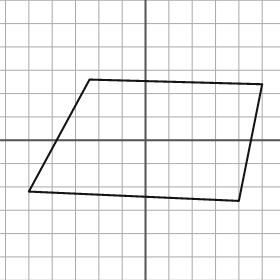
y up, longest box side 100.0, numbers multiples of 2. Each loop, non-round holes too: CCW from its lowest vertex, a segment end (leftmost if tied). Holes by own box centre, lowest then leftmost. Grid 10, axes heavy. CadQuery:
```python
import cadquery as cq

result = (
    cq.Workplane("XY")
    .moveTo(40.0, -26.0)
    .lineTo(50.0, 24.0)
    .lineTo(-24.0, 26.0)
    .lineTo(-50.0, -22.0)
    .close()
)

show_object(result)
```